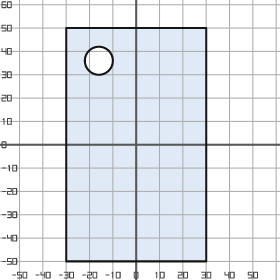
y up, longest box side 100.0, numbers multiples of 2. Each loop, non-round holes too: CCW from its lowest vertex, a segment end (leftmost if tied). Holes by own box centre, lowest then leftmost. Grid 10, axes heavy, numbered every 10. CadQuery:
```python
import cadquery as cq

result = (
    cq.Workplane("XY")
    .moveTo(-30.0, -50.0)
    .lineTo(30.0, -50.0)
    .lineTo(30.0, 50.0)
    .lineTo(-30.0, 50.0)
    .close()
    .moveTo(-16.0, 36.0)
    .circle(6.0)
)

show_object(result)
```